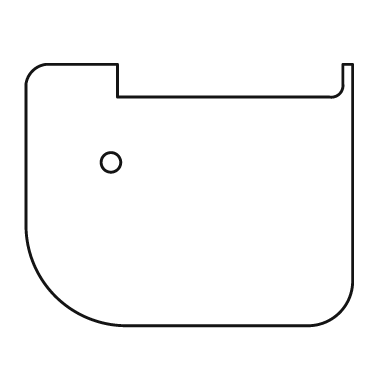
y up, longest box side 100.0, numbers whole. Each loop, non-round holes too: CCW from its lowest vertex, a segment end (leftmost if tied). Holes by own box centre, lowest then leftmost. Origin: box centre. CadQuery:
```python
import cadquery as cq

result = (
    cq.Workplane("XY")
    .moveTo(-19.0, -40.0)
    .lineTo(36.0, -40.0)
    .threePointArc((46.0, -36.0), (50.0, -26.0))
    .lineTo(50.0, 40.0)
    .lineTo(47.0, 40.0)
    .lineTo(47.0, 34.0)
    .threePointArc((46.0, 31.0), (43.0, 30.0))
    .lineTo(-22.0, 30.0)
    .lineTo(-22.0, 40.0)
    .lineTo(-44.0, 40.0)
    .threePointArc((-48.0, 38.0), (-50.0, 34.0))
    .lineTo(-50.0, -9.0)
    .threePointArc((-41.0, -31.0), (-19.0, -40.0))
    .close()
    .moveTo(-24.0, 10.0)
    .circle(3.0)
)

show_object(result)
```